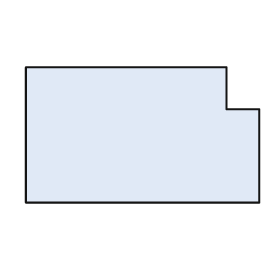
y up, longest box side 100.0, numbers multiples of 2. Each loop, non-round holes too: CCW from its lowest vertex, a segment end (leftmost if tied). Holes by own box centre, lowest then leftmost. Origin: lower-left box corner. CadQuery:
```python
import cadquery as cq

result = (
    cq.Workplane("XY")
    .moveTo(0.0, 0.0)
    .lineTo(100.0, 0.0)
    .lineTo(100.0, 40.0)
    .lineTo(86.0, 40.0)
    .lineTo(86.0, 58.0)
    .lineTo(0.0, 58.0)
    .close()
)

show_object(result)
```